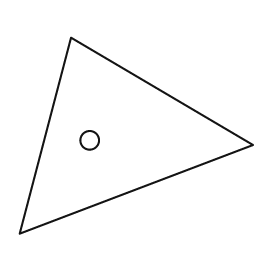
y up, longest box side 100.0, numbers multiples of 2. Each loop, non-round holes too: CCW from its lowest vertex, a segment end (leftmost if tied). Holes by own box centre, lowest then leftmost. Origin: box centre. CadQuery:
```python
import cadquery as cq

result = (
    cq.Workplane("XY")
    .moveTo(-50.0, -42.0)
    .lineTo(50.0, -4.0)
    .lineTo(-28.0, 42.0)
    .close()
    .moveTo(-20.0, -2.0)
    .circle(4.0)
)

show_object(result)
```